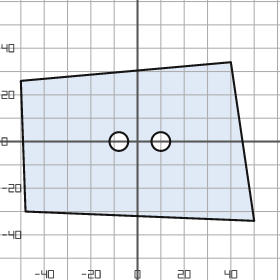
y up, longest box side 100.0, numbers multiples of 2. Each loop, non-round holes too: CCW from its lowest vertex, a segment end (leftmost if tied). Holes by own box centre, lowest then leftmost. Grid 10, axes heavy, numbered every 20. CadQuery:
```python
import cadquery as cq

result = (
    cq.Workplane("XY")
    .moveTo(50.0, -34.0)
    .lineTo(40.0, 34.0)
    .lineTo(-50.0, 26.0)
    .lineTo(-48.0, -30.0)
    .close()
    .moveTo(-8.0, 0.0)
    .circle(4.0)
    .moveTo(10.0, 0.0)
    .circle(4.0)
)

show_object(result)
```